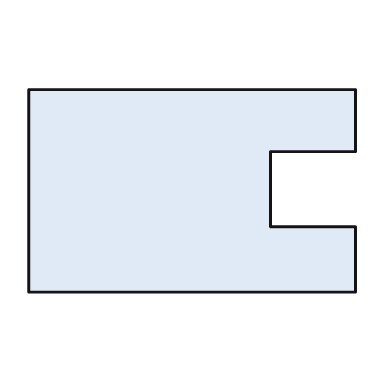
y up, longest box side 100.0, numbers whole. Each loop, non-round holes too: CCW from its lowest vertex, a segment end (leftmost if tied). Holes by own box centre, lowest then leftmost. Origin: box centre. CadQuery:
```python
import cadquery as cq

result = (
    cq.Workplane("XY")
    .moveTo(-50.0, -31.0)
    .lineTo(50.0, -31.0)
    .lineTo(50.0, -11.0)
    .lineTo(24.0, -11.0)
    .lineTo(24.0, 12.0)
    .lineTo(50.0, 12.0)
    .lineTo(50.0, 31.0)
    .lineTo(-50.0, 31.0)
    .close()
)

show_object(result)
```